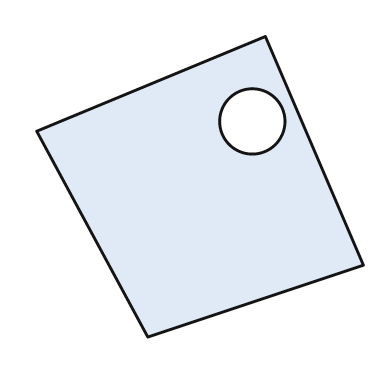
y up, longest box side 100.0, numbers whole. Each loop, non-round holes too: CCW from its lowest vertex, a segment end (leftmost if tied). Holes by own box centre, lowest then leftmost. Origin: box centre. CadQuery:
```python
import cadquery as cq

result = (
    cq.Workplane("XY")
    .moveTo(-16.0, -46.0)
    .lineTo(50.0, -24.0)
    .lineTo(20.0, 46.0)
    .lineTo(-50.0, 17.0)
    .close()
    .moveTo(16.0, 20.0)
    .circle(10.0)
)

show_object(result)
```